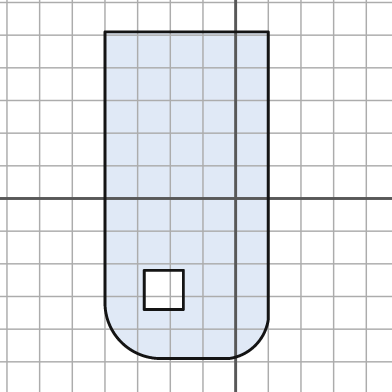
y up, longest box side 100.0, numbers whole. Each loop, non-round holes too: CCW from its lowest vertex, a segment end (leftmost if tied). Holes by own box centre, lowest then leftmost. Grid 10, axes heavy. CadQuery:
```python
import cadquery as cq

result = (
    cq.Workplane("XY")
    .moveTo(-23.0, -49.0)
    .lineTo(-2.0, -49.0)
    .threePointArc((6.0, -45.0), (10.0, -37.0))
    .lineTo(10.0, 51.0)
    .lineTo(-40.0, 51.0)
    .lineTo(-40.0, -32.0)
    .threePointArc((-35.0, -44.0), (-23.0, -49.0))
    .close()
    .moveTo(-28.0, -34.0)
    .lineTo(-16.0, -34.0)
    .lineTo(-16.0, -22.0)
    .lineTo(-28.0, -22.0)
    .close()
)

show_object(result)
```